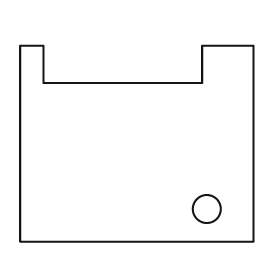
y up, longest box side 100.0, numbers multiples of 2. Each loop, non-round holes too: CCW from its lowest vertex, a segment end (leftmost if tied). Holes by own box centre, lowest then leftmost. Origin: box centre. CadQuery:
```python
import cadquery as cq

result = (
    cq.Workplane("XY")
    .moveTo(-50.0, -42.0)
    .lineTo(50.0, -42.0)
    .lineTo(50.0, 42.0)
    .lineTo(28.0, 42.0)
    .lineTo(28.0, 26.0)
    .lineTo(-40.0, 26.0)
    .lineTo(-40.0, 42.0)
    .lineTo(-50.0, 42.0)
    .close()
    .moveTo(30.0, -28.0)
    .circle(6.0)
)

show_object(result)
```